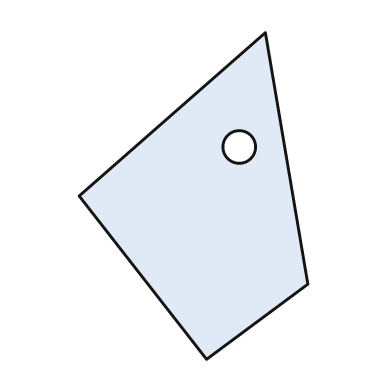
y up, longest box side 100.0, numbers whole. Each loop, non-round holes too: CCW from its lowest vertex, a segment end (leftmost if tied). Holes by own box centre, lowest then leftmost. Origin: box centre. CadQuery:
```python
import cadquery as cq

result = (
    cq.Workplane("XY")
    .moveTo(4.0, -50.0)
    .lineTo(35.0, -27.0)
    .lineTo(22.0, 50.0)
    .lineTo(-35.0, 0.0)
    .close()
    .moveTo(14.0, 15.0)
    .circle(5.0)
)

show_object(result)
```